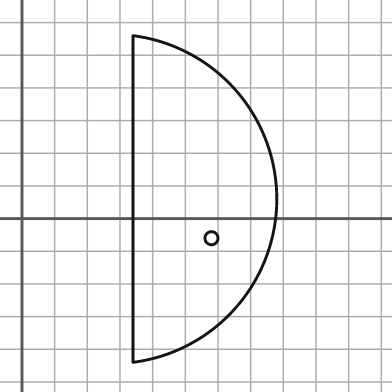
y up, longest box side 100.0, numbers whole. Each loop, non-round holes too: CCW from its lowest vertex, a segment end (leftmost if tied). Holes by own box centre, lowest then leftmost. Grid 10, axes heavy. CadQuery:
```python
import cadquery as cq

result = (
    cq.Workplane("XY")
    .moveTo(34.0, -44.0)
    .threePointArc((78.0, 6.0), (34.0, 56.0))
    .close()
    .moveTo(58.0, -6.0)
    .circle(2.0)
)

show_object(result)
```